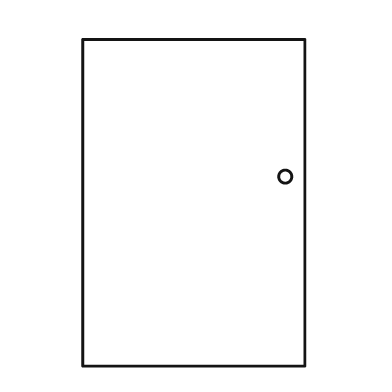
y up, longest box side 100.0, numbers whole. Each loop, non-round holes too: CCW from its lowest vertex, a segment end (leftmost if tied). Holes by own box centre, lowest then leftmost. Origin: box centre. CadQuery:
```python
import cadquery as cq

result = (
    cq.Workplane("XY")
    .moveTo(-34.0, -50.0)
    .lineTo(34.0, -50.0)
    .lineTo(34.0, 50.0)
    .lineTo(-34.0, 50.0)
    .close()
    .moveTo(28.0, 8.0)
    .circle(2.0)
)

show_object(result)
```